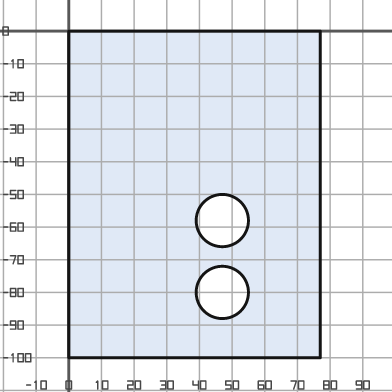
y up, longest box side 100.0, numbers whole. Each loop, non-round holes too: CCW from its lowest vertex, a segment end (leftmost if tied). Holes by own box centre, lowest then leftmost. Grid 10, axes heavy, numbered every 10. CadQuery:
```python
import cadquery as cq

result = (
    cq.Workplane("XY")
    .moveTo(0.0, -100.0)
    .lineTo(77.0, -100.0)
    .lineTo(77.0, 0.0)
    .lineTo(0.0, 0.0)
    .close()
    .moveTo(47.0, -80.0)
    .circle(8.0)
    .moveTo(47.0, -58.0)
    .circle(8.0)
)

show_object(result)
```